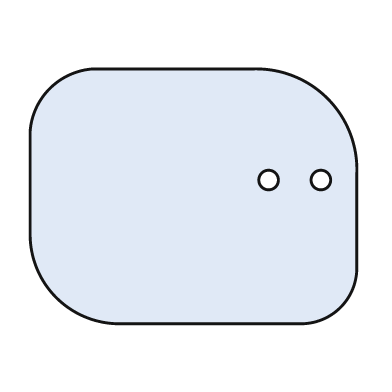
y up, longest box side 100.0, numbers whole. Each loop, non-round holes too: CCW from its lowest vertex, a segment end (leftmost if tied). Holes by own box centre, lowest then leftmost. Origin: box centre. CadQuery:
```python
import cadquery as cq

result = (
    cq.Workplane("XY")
    .moveTo(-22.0, -39.0)
    .lineTo(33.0, -39.0)
    .threePointArc((45.0, -34.0), (50.0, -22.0))
    .lineTo(50.0, 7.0)
    .threePointArc((41.0, 30.0), (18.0, 39.0))
    .lineTo(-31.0, 39.0)
    .threePointArc((-44.0, 33.0), (-50.0, 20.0))
    .lineTo(-50.0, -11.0)
    .threePointArc((-42.0, -31.0), (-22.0, -39.0))
    .close()
    .moveTo(23.0, 5.0)
    .circle(3.0)
    .moveTo(39.0, 5.0)
    .circle(3.0)
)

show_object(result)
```